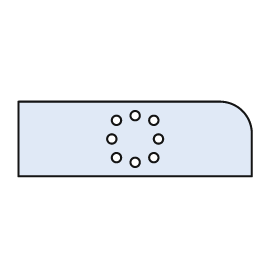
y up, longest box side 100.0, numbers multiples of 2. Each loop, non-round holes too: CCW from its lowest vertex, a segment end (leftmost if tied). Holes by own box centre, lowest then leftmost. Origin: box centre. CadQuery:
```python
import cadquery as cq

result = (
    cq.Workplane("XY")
    .moveTo(-50.0, -16.0)
    .lineTo(50.0, -16.0)
    .lineTo(50.0, 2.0)
    .threePointArc((46.0, 12.0), (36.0, 16.0))
    .lineTo(-50.0, 16.0)
    .close()
    .moveTo(0.0, -10.0)
    .circle(2.0)
    .moveTo(-8.0, -8.0)
    .circle(2.0)
    .moveTo(8.0, -8.0)
    .circle(2.0)
    .moveTo(-10.0, 0.0)
    .circle(2.0)
    .moveTo(10.0, 0.0)
    .circle(2.0)
    .moveTo(-8.0, 8.0)
    .circle(2.0)
    .moveTo(8.0, 8.0)
    .circle(2.0)
    .moveTo(0.0, 10.0)
    .circle(2.0)
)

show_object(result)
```